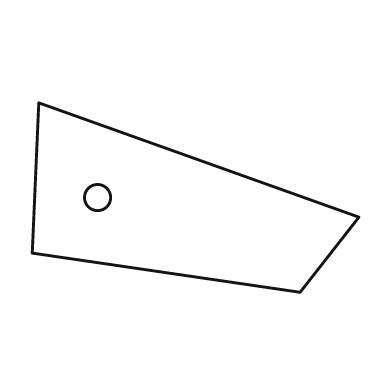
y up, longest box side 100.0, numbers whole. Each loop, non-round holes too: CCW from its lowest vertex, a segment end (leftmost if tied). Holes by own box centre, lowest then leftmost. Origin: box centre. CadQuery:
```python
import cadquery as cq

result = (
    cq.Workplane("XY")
    .moveTo(32.0, -29.0)
    .lineTo(50.0, -6.0)
    .lineTo(-48.0, 29.0)
    .lineTo(-50.0, -17.0)
    .close()
    .moveTo(-30.0, 0.0)
    .circle(4.0)
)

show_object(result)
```